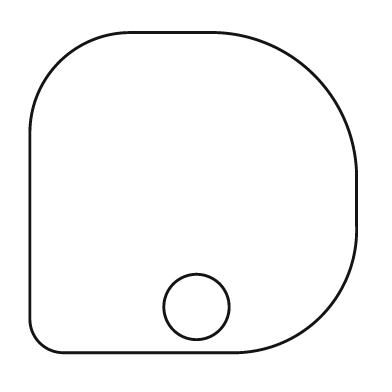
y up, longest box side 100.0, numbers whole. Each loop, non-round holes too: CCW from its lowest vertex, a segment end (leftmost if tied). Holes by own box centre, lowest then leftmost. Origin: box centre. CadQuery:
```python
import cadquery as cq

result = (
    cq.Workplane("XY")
    .moveTo(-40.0, -49.0)
    .lineTo(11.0, -49.0)
    .threePointArc((39.0, -38.0), (50.0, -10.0))
    .lineTo(50.0, 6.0)
    .threePointArc((37.0, 36.0), (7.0, 49.0))
    .lineTo(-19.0, 49.0)
    .threePointArc((-41.0, 40.0), (-50.0, 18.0))
    .lineTo(-50.0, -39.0)
    .threePointArc((-47.0, -46.0), (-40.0, -49.0))
    .close()
    .moveTo(1.0, -35.0)
    .circle(10.0)
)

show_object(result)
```